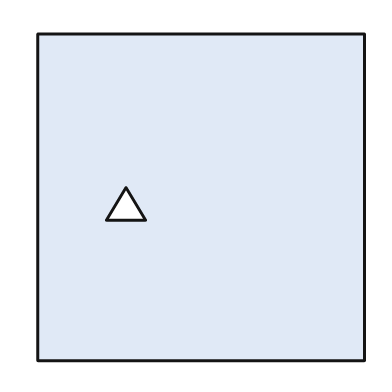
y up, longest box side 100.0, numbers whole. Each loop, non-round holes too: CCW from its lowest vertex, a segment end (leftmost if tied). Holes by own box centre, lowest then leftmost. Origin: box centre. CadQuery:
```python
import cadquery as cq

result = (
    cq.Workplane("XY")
    .moveTo(-50.0, -50.0)
    .lineTo(50.0, -50.0)
    .lineTo(50.0, 50.0)
    .lineTo(-50.0, 50.0)
    .close()
    .moveTo(-29.0, -7.0)
    .lineTo(-17.0, -7.0)
    .lineTo(-23.0, 3.0)
    .close()
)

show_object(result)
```